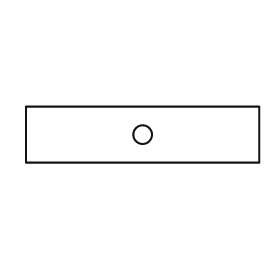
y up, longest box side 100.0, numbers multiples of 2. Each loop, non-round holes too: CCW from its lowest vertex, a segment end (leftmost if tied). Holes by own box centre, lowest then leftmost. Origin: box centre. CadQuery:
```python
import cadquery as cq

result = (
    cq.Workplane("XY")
    .moveTo(-50.0, -12.0)
    .lineTo(50.0, -12.0)
    .lineTo(50.0, 12.0)
    .lineTo(-50.0, 12.0)
    .close()
    .moveTo(0.0, 0.0)
    .circle(4.0)
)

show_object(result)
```